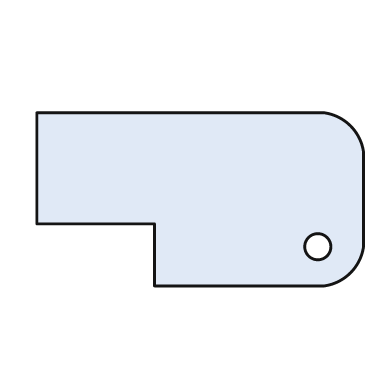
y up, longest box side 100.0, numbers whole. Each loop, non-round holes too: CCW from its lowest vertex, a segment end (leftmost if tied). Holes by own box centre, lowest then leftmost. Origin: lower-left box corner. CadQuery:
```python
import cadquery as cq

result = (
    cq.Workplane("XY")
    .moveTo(36.0, 0.0)
    .lineTo(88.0, 0.0)
    .threePointArc((96.0, 4.0), (100.0, 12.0))
    .lineTo(100.0, 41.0)
    .threePointArc((96.0, 49.0), (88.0, 53.0))
    .lineTo(0.0, 53.0)
    .lineTo(0.0, 19.0)
    .lineTo(36.0, 19.0)
    .close()
    .moveTo(86.0, 12.0)
    .circle(4.0)
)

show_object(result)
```